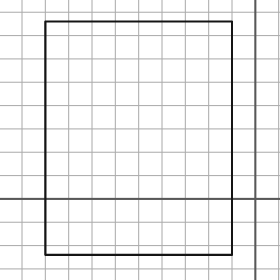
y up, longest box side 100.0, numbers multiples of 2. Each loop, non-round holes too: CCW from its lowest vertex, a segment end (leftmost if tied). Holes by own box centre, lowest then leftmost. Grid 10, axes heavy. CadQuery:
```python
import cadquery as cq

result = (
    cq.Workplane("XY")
    .moveTo(-90.0, -24.0)
    .lineTo(-10.0, -24.0)
    .lineTo(-10.0, 76.0)
    .lineTo(-90.0, 76.0)
    .close()
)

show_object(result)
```